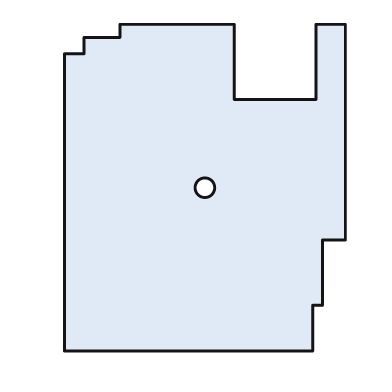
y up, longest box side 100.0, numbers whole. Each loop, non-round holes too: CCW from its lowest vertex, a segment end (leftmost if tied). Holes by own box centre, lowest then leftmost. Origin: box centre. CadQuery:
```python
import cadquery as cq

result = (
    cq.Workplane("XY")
    .moveTo(-43.0, -50.0)
    .lineTo(33.0, -50.0)
    .lineTo(33.0, -36.0)
    .lineTo(36.0, -36.0)
    .lineTo(36.0, -16.0)
    .lineTo(43.0, -16.0)
    .lineTo(43.0, 50.0)
    .lineTo(34.0, 50.0)
    .lineTo(34.0, 27.0)
    .lineTo(9.0, 27.0)
    .lineTo(9.0, 50.0)
    .lineTo(-26.0, 50.0)
    .lineTo(-26.0, 46.0)
    .lineTo(-37.0, 46.0)
    .lineTo(-37.0, 41.0)
    .lineTo(-43.0, 41.0)
    .close()
    .moveTo(0.0, 0.0)
    .circle(3.0)
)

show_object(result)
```